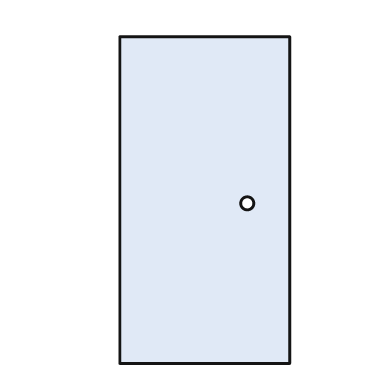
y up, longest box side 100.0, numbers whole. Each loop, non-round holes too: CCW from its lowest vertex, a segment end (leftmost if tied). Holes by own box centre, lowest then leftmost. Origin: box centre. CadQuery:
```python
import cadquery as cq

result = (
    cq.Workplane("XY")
    .moveTo(-26.0, -50.0)
    .lineTo(26.0, -50.0)
    .lineTo(26.0, 50.0)
    .lineTo(-26.0, 50.0)
    .close()
    .moveTo(13.0, -1.0)
    .circle(2.0)
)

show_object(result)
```